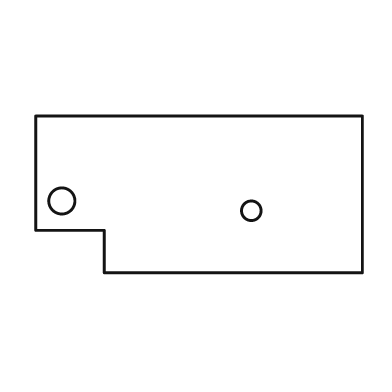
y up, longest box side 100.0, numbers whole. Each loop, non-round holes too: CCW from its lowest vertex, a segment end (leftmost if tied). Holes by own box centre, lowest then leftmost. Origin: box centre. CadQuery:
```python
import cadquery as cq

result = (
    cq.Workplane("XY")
    .moveTo(-29.0, -24.0)
    .lineTo(50.0, -24.0)
    .lineTo(50.0, 24.0)
    .lineTo(-50.0, 24.0)
    .lineTo(-50.0, -11.0)
    .lineTo(-29.0, -11.0)
    .close()
    .moveTo(16.0, -5.0)
    .circle(3.0)
    .moveTo(-42.0, -2.0)
    .circle(4.0)
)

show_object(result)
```